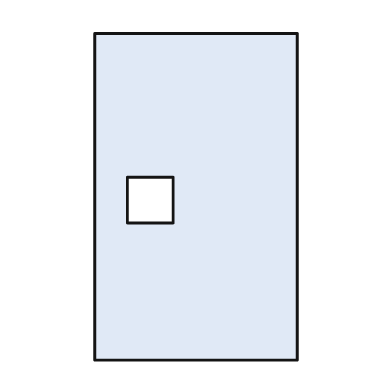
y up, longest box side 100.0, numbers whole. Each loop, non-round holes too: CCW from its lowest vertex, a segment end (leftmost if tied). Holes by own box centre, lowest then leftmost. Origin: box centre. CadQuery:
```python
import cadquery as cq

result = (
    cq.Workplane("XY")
    .moveTo(-31.0, -50.0)
    .lineTo(31.0, -50.0)
    .lineTo(31.0, 50.0)
    .lineTo(-31.0, 50.0)
    .close()
    .moveTo(-21.0, -8.0)
    .lineTo(-7.0, -8.0)
    .lineTo(-7.0, 6.0)
    .lineTo(-21.0, 6.0)
    .close()
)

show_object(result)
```